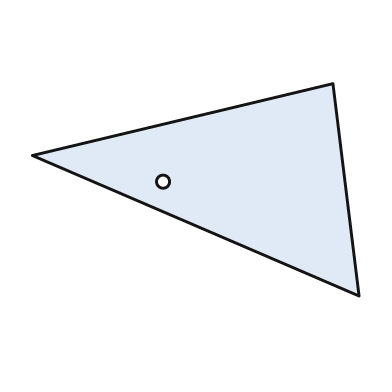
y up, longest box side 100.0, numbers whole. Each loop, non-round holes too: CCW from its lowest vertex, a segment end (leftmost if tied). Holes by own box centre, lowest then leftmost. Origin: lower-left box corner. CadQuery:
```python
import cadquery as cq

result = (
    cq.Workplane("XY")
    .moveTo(100.0, 0.0)
    .lineTo(92.0, 65.0)
    .lineTo(0.0, 43.0)
    .close()
    .moveTo(40.0, 35.0)
    .circle(2.0)
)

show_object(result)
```